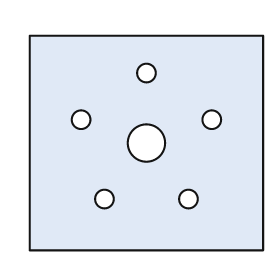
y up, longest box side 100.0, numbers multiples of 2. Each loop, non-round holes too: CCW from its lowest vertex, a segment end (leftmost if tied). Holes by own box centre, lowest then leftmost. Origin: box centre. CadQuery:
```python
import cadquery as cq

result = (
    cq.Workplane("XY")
    .moveTo(-50.0, -46.0)
    .lineTo(50.0, -46.0)
    .lineTo(50.0, 46.0)
    .lineTo(-50.0, 46.0)
    .close()
    .moveTo(-18.0, -24.0)
    .circle(4.0)
    .moveTo(18.0, -24.0)
    .circle(4.0)
    .moveTo(0.0, 0.0)
    .circle(8.0)
    .moveTo(-28.0, 10.0)
    .circle(4.0)
    .moveTo(28.0, 10.0)
    .circle(4.0)
    .moveTo(0.0, 30.0)
    .circle(4.0)
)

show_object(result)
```